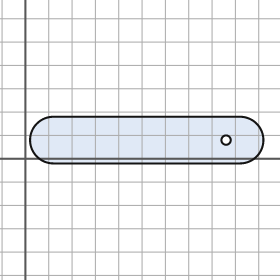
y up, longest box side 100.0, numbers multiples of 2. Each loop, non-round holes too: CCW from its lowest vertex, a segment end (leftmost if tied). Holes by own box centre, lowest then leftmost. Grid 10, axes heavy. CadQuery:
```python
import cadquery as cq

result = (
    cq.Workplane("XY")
    .moveTo(12.0, -2.0)
    .lineTo(92.0, -2.0)
    .threePointArc((102.0, 8.0), (92.0, 18.0))
    .lineTo(12.0, 18.0)
    .threePointArc((2.0, 8.0), (12.0, -2.0))
    .close()
    .moveTo(86.0, 8.0)
    .circle(2.0)
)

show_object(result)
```